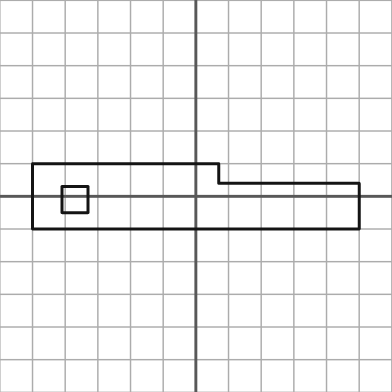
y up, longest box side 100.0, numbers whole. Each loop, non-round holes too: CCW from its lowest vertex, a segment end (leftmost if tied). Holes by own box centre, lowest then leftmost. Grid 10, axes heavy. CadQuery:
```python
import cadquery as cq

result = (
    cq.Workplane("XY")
    .moveTo(-50.0, -10.0)
    .lineTo(50.0, -10.0)
    .lineTo(50.0, 4.0)
    .lineTo(7.0, 4.0)
    .lineTo(7.0, 10.0)
    .lineTo(-50.0, 10.0)
    .close()
    .moveTo(-41.0, -5.0)
    .lineTo(-33.0, -5.0)
    .lineTo(-33.0, 3.0)
    .lineTo(-41.0, 3.0)
    .close()
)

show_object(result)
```